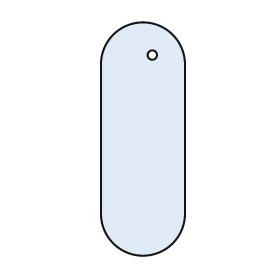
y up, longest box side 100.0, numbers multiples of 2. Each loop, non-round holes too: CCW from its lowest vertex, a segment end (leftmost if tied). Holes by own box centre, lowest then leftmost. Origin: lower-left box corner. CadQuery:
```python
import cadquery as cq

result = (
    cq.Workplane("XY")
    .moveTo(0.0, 18.0)
    .threePointArc((18.0, 0.0), (36.0, 18.0))
    .lineTo(36.0, 82.0)
    .threePointArc((18.0, 100.0), (0.0, 82.0))
    .close()
    .moveTo(22.0, 86.0)
    .circle(2.0)
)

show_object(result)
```